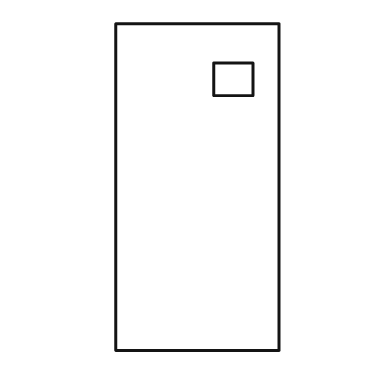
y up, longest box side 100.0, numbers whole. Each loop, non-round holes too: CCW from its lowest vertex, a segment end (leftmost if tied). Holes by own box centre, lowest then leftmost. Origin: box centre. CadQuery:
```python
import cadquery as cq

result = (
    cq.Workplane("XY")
    .moveTo(-25.0, -50.0)
    .lineTo(25.0, -50.0)
    .lineTo(25.0, 50.0)
    .lineTo(-25.0, 50.0)
    .close()
    .moveTo(5.0, 28.0)
    .lineTo(17.0, 28.0)
    .lineTo(17.0, 38.0)
    .lineTo(5.0, 38.0)
    .close()
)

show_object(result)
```